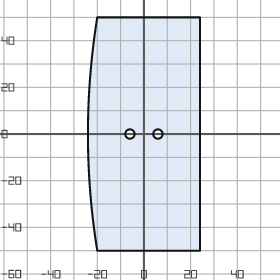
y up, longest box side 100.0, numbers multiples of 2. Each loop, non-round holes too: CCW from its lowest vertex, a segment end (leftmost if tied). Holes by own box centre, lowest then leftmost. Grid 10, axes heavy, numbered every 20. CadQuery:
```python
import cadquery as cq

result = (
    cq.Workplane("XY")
    .moveTo(-20.0, -50.0)
    .lineTo(24.0, -50.0)
    .lineTo(24.0, 50.0)
    .lineTo(-20.0, 50.0)
    .threePointArc((-24.0, 0.0), (-20.0, -50.0))
    .close()
    .moveTo(-6.0, 0.0)
    .circle(2.0)
    .moveTo(6.0, 0.0)
    .circle(2.0)
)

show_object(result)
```